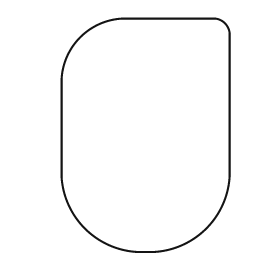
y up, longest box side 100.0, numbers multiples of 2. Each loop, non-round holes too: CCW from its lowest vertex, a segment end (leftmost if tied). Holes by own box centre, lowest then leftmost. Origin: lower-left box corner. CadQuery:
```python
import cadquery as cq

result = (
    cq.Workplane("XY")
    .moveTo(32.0, 0.0)
    .lineTo(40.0, 0.0)
    .threePointArc((62.0, 10.0), (72.0, 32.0))
    .lineTo(72.0, 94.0)
    .threePointArc((70.0, 98.0), (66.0, 100.0))
    .lineTo(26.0, 100.0)
    .threePointArc((8.0, 92.0), (0.0, 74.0))
    .lineTo(0.0, 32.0)
    .threePointArc((10.0, 10.0), (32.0, 0.0))
    .close()
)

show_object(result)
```